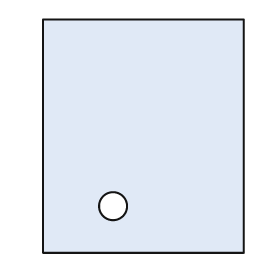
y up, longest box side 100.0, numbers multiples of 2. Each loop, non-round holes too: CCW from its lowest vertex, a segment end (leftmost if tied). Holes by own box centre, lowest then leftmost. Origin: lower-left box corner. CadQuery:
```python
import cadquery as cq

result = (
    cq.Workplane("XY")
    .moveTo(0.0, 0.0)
    .lineTo(86.0, 0.0)
    .lineTo(86.0, 100.0)
    .lineTo(0.0, 100.0)
    .close()
    .moveTo(30.0, 20.0)
    .circle(6.0)
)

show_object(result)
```